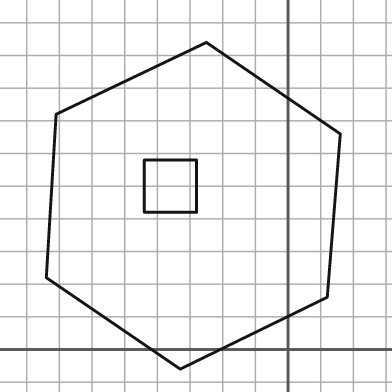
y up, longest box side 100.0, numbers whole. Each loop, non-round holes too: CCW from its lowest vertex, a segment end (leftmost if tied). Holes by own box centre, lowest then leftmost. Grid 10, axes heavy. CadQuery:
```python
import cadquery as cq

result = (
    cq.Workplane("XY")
    .moveTo(-33.0, -6.0)
    .lineTo(12.0, 16.0)
    .lineTo(16.0, 66.0)
    .lineTo(-25.0, 94.0)
    .lineTo(-71.0, 72.0)
    .lineTo(-74.0, 22.0)
    .close()
    .moveTo(-44.0, 42.0)
    .lineTo(-28.0, 42.0)
    .lineTo(-28.0, 58.0)
    .lineTo(-44.0, 58.0)
    .close()
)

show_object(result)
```